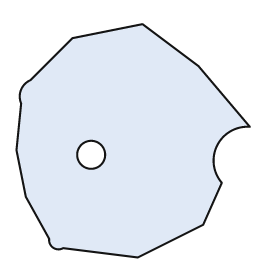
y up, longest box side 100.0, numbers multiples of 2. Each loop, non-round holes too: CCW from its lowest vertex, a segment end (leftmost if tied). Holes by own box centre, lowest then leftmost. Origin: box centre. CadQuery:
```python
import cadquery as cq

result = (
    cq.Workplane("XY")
    .moveTo(2.0, -50.0)
    .lineTo(30.0, -36.0)
    .lineTo(38.0, -18.0)
    .threePointArc((36.0, -2.0), (50.0, 6.0))
    .lineTo(28.0, 32.0)
    .lineTo(4.0, 50.0)
    .lineTo(-26.0, 44.0)
    .lineTo(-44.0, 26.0)
    .threePointArc((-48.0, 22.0), (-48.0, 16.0))
    .lineTo(-50.0, -4.0)
    .lineTo(-46.0, -24.0)
    .lineTo(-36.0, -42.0)
    .threePointArc((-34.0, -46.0), (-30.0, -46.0))
    .close()
    .moveTo(-18.0, -6.0)
    .circle(6.0)
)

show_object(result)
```